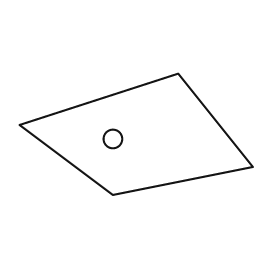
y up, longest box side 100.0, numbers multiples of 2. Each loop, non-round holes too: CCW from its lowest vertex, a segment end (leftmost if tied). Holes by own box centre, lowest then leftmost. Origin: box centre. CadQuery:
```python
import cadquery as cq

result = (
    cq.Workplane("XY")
    .moveTo(-10.0, -26.0)
    .lineTo(50.0, -14.0)
    .lineTo(18.0, 26.0)
    .lineTo(-50.0, 4.0)
    .close()
    .moveTo(-10.0, -2.0)
    .circle(4.0)
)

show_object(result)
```